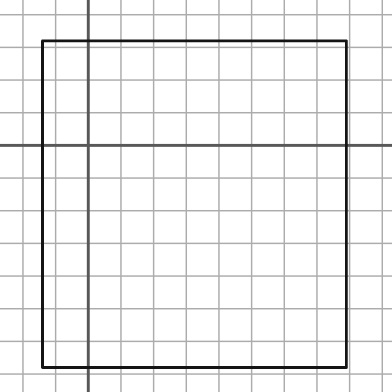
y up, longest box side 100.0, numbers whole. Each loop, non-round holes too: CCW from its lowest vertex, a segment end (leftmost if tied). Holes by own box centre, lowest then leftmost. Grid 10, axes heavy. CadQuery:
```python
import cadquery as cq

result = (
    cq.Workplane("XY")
    .moveTo(-14.0, -68.0)
    .lineTo(79.0, -68.0)
    .lineTo(79.0, 32.0)
    .lineTo(-14.0, 32.0)
    .close()
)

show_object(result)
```